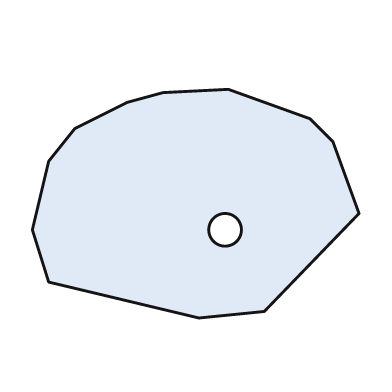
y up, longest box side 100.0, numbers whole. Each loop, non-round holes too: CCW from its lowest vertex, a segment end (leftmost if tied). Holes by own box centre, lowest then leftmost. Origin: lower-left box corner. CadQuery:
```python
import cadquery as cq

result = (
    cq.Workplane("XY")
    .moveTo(51.0, 0.0)
    .lineTo(71.0, 2.0)
    .lineTo(100.0, 32.0)
    .lineTo(92.0, 54.0)
    .lineTo(85.0, 61.0)
    .lineTo(60.0, 70.0)
    .lineTo(40.0, 69.0)
    .lineTo(29.0, 66.0)
    .lineTo(13.0, 58.0)
    .lineTo(5.0, 48.0)
    .lineTo(0.0, 27.0)
    .lineTo(5.0, 11.0)
    .close()
    .moveTo(59.0, 27.0)
    .circle(5.0)
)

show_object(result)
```